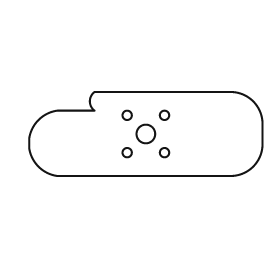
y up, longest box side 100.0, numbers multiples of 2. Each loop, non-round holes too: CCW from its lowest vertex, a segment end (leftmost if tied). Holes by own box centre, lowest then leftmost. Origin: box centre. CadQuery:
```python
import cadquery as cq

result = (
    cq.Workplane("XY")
    .moveTo(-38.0, -18.0)
    .lineTo(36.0, -18.0)
    .threePointArc((46.0, -14.0), (50.0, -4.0))
    .lineTo(50.0, 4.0)
    .threePointArc((46.0, 14.0), (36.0, 18.0))
    .lineTo(-22.0, 18.0)
    .threePointArc((-24.0, 14.0), (-22.0, 10.0))
    .lineTo(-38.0, 10.0)
    .threePointArc((-46.0, 6.0), (-50.0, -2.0))
    .lineTo(-50.0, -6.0)
    .threePointArc((-46.0, -14.0), (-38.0, -18.0))
    .close()
    .moveTo(-8.0, -8.0)
    .circle(2.0)
    .moveTo(8.0, -8.0)
    .circle(2.0)
    .moveTo(0.0, 0.0)
    .circle(4.0)
    .moveTo(-8.0, 8.0)
    .circle(2.0)
    .moveTo(8.0, 8.0)
    .circle(2.0)
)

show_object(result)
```